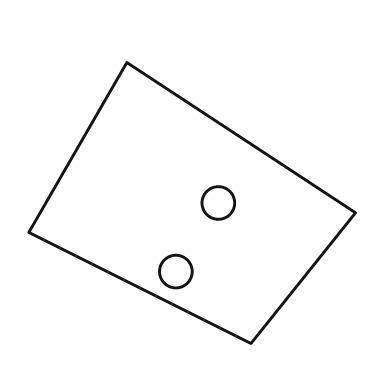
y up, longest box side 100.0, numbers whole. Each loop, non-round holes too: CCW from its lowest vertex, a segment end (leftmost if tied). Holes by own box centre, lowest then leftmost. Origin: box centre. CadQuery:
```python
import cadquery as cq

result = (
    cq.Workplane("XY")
    .moveTo(18.0, -43.0)
    .lineTo(50.0, -3.0)
    .lineTo(-20.0, 43.0)
    .lineTo(-50.0, -9.0)
    .close()
    .moveTo(-5.0, -21.0)
    .circle(5.0)
    .moveTo(8.0, 0.0)
    .circle(5.0)
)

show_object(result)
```